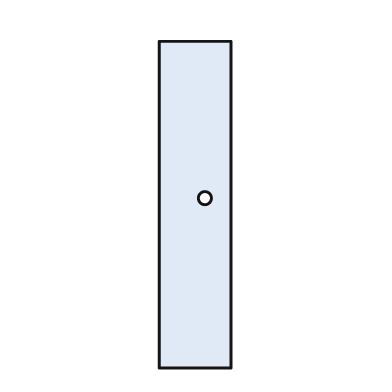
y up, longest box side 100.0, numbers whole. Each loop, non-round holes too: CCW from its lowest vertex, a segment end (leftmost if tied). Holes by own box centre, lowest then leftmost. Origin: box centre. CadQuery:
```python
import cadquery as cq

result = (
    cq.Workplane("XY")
    .moveTo(-11.0, -50.0)
    .lineTo(11.0, -50.0)
    .lineTo(11.0, 50.0)
    .lineTo(-11.0, 50.0)
    .close()
    .moveTo(3.0, 2.0)
    .circle(2.0)
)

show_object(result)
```